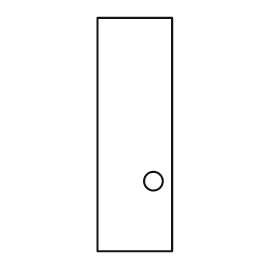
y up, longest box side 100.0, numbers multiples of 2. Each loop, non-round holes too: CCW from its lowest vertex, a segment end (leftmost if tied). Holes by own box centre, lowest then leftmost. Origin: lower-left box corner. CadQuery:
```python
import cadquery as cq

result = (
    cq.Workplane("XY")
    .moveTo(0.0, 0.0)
    .lineTo(32.0, 0.0)
    .lineTo(32.0, 100.0)
    .lineTo(0.0, 100.0)
    .close()
    .moveTo(24.0, 30.0)
    .circle(4.0)
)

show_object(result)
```